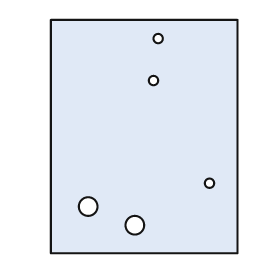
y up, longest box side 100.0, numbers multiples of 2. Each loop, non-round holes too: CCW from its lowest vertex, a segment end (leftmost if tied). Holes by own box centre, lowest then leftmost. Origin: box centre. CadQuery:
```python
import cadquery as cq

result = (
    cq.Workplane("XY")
    .moveTo(-40.0, -50.0)
    .lineTo(40.0, -50.0)
    .lineTo(40.0, 50.0)
    .lineTo(-40.0, 50.0)
    .close()
    .moveTo(-4.0, -38.0)
    .circle(4.0)
    .moveTo(-24.0, -30.0)
    .circle(4.0)
    .moveTo(28.0, -20.0)
    .circle(2.0)
    .moveTo(4.0, 24.0)
    .circle(2.0)
    .moveTo(6.0, 42.0)
    .circle(2.0)
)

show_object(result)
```